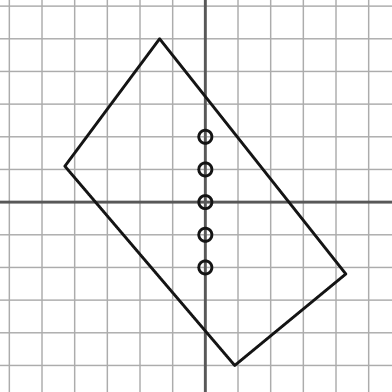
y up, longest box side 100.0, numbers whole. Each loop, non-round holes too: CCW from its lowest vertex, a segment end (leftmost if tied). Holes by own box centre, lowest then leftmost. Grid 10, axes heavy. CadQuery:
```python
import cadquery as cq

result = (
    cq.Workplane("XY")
    .moveTo(9.0, -50.0)
    .lineTo(43.0, -22.0)
    .lineTo(-14.0, 50.0)
    .lineTo(-43.0, 11.0)
    .close()
    .moveTo(0.0, -20.0)
    .circle(2.0)
    .moveTo(0.0, -10.0)
    .circle(2.0)
    .moveTo(0.0, 0.0)
    .circle(2.0)
    .moveTo(0.0, 10.0)
    .circle(2.0)
    .moveTo(0.0, 20.0)
    .circle(2.0)
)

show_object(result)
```